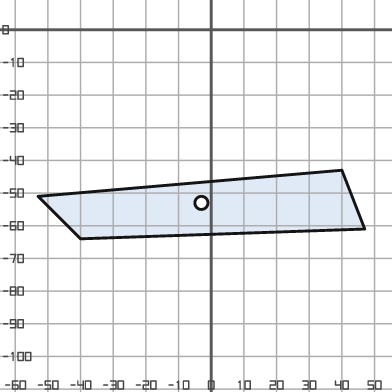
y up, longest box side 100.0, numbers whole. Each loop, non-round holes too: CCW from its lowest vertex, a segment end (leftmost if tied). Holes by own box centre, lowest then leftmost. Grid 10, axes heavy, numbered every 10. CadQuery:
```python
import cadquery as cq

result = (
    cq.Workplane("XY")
    .moveTo(-40.0, -64.0)
    .lineTo(47.0, -61.0)
    .lineTo(40.0, -43.0)
    .lineTo(-53.0, -51.0)
    .close()
    .moveTo(-3.0, -53.0)
    .circle(2.0)
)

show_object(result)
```